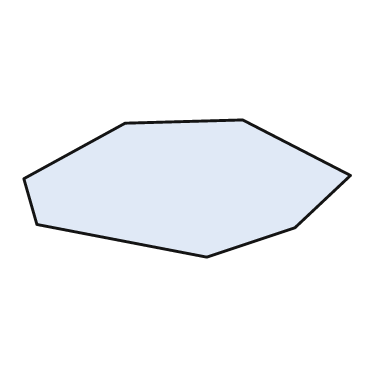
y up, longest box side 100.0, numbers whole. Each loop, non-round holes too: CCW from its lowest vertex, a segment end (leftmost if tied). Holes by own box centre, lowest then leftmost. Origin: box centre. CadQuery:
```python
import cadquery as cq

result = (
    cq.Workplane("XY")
    .moveTo(6.0, -21.0)
    .lineTo(33.0, -12.0)
    .lineTo(50.0, 4.0)
    .lineTo(17.0, 21.0)
    .lineTo(-19.0, 20.0)
    .lineTo(-50.0, 3.0)
    .lineTo(-46.0, -11.0)
    .close()
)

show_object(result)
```